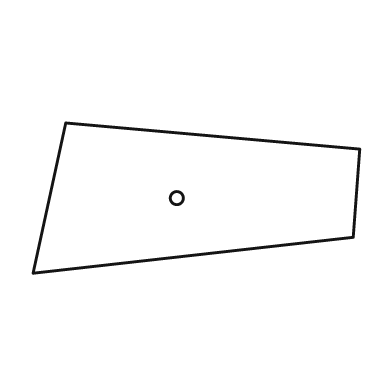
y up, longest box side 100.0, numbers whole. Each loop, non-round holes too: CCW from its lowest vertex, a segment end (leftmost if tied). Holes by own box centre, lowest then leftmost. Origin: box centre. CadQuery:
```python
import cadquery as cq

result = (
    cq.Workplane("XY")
    .moveTo(-50.0, -23.0)
    .lineTo(48.0, -12.0)
    .lineTo(50.0, 15.0)
    .lineTo(-40.0, 23.0)
    .close()
    .moveTo(-6.0, 0.0)
    .circle(2.0)
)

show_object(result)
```